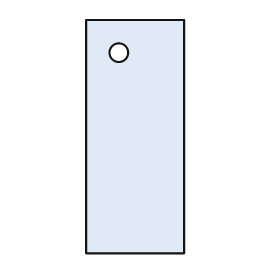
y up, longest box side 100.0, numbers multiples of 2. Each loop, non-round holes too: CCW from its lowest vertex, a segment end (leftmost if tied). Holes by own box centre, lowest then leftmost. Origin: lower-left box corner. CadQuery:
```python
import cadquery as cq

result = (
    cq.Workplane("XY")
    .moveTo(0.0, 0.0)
    .lineTo(42.0, 0.0)
    .lineTo(42.0, 100.0)
    .lineTo(0.0, 100.0)
    .close()
    .moveTo(14.0, 86.0)
    .circle(4.0)
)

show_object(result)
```